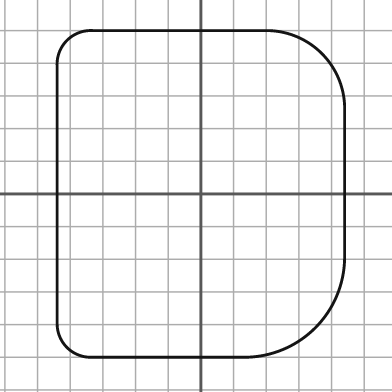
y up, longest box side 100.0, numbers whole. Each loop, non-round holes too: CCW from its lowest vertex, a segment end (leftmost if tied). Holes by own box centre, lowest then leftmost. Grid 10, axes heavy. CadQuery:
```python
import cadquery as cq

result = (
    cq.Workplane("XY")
    .moveTo(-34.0, -50.0)
    .lineTo(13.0, -50.0)
    .threePointArc((35.0, -41.0), (44.0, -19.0))
    .lineTo(44.0, 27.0)
    .threePointArc((37.0, 43.0), (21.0, 50.0))
    .lineTo(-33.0, 50.0)
    .threePointArc((-41.0, 47.0), (-44.0, 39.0))
    .lineTo(-44.0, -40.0)
    .threePointArc((-41.0, -47.0), (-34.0, -50.0))
    .close()
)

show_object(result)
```